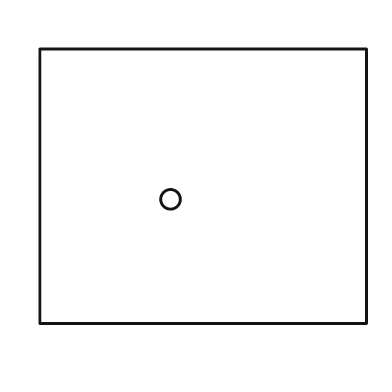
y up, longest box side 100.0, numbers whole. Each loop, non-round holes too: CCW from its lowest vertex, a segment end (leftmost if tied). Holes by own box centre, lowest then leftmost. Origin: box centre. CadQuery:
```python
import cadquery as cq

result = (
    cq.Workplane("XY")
    .moveTo(-50.0, -42.0)
    .lineTo(50.0, -42.0)
    .lineTo(50.0, 42.0)
    .lineTo(-50.0, 42.0)
    .close()
    .moveTo(-10.0, -4.0)
    .circle(3.0)
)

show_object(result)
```